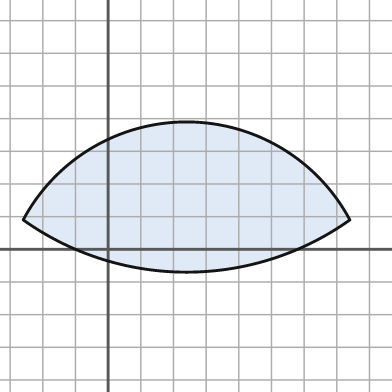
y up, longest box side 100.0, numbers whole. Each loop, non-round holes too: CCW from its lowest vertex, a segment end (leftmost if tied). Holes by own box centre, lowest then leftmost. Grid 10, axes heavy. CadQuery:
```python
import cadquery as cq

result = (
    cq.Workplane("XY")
    .moveTo(-26.0, 9.0)
    .threePointArc((24.0, -7.0), (74.0, 9.0))
    .threePointArc((24.0, 39.0), (-26.0, 9.0))
    .close()
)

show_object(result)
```